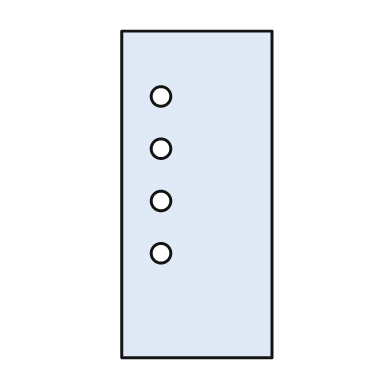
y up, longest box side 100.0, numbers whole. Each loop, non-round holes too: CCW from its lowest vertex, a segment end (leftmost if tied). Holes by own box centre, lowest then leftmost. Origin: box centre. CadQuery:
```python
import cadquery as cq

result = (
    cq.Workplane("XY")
    .moveTo(-23.0, -50.0)
    .lineTo(23.0, -50.0)
    .lineTo(23.0, 50.0)
    .lineTo(-23.0, 50.0)
    .close()
    .moveTo(-11.0, -18.0)
    .circle(3.0)
    .moveTo(-11.0, -2.0)
    .circle(3.0)
    .moveTo(-11.0, 14.0)
    .circle(3.0)
    .moveTo(-11.0, 30.0)
    .circle(3.0)
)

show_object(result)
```